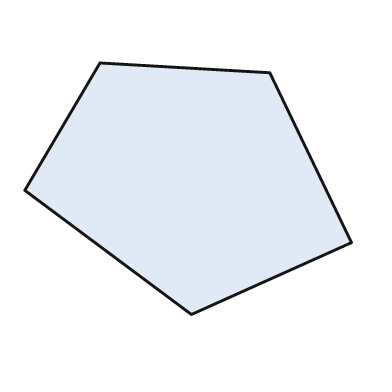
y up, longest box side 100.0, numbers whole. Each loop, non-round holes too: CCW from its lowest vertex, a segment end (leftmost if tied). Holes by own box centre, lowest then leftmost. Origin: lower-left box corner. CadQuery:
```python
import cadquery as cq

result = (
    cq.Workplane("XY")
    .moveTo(51.0, 0.0)
    .lineTo(100.0, 22.0)
    .lineTo(75.0, 74.0)
    .lineTo(23.0, 77.0)
    .lineTo(0.0, 38.0)
    .close()
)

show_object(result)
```